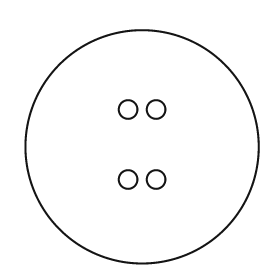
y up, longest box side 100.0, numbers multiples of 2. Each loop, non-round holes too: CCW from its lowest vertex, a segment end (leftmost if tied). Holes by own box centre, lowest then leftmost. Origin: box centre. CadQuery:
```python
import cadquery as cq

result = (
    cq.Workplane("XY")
    .moveTo(0.0, 0.0)
    .circle(50.0)
    .moveTo(-6.0, -14.0)
    .circle(4.0)
    .moveTo(6.0, -14.0)
    .circle(4.0)
    .moveTo(-6.0, 16.0)
    .circle(4.0)
    .moveTo(6.0, 16.0)
    .circle(4.0)
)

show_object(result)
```